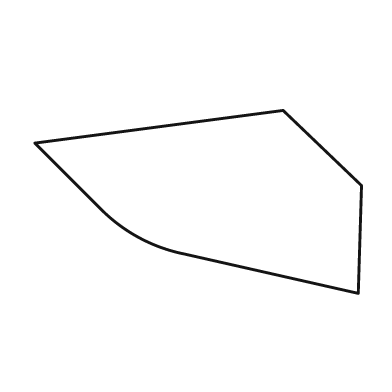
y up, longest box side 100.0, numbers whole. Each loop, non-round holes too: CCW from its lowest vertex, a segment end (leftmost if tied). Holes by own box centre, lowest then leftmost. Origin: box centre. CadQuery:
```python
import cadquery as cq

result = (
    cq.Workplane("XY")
    .moveTo(49.0, -28.0)
    .lineTo(50.0, 5.0)
    .lineTo(26.0, 28.0)
    .lineTo(-50.0, 18.0)
    .lineTo(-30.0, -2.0)
    .threePointArc((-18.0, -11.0), (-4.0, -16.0))
    .close()
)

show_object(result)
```